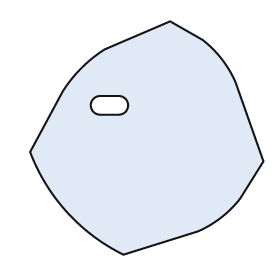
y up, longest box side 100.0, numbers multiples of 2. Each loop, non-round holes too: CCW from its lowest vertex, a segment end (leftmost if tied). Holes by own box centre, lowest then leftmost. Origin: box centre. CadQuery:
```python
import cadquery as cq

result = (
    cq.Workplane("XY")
    .moveTo(-10.0, -50.0)
    .lineTo(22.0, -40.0)
    .threePointArc((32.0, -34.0), (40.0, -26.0))
    .lineTo(50.0, -10.0)
    .lineTo(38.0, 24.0)
    .threePointArc((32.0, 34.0), (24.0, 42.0))
    .lineTo(10.0, 50.0)
    .lineTo(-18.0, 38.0)
    .threePointArc((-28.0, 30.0), (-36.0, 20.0))
    .lineTo(-50.0, -6.0)
    .threePointArc((-34.0, -32.0), (-10.0, -50.0))
    .close()
    .moveTo(-20.0, 10.0)
    .lineTo(-12.0, 10.0)
    .threePointArc((-8.0, 14.0), (-12.0, 18.0))
    .lineTo(-20.0, 18.0)
    .threePointArc((-24.0, 14.0), (-20.0, 10.0))
    .close()
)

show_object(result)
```